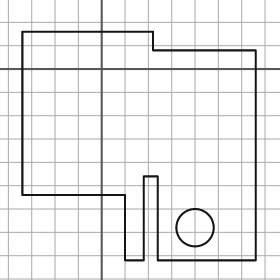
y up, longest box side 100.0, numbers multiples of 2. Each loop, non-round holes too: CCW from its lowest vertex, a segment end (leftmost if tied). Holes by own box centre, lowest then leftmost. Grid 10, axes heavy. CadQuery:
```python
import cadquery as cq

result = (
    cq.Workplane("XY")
    .moveTo(10.0, -82.0)
    .lineTo(18.0, -82.0)
    .lineTo(18.0, -46.0)
    .lineTo(24.0, -46.0)
    .lineTo(24.0, -82.0)
    .lineTo(66.0, -82.0)
    .lineTo(66.0, 8.0)
    .lineTo(22.0, 8.0)
    .lineTo(22.0, 16.0)
    .lineTo(-34.0, 16.0)
    .lineTo(-34.0, -54.0)
    .lineTo(10.0, -54.0)
    .close()
    .moveTo(40.0, -68.0)
    .circle(8.0)
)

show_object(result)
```